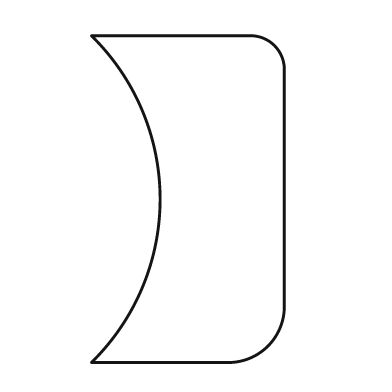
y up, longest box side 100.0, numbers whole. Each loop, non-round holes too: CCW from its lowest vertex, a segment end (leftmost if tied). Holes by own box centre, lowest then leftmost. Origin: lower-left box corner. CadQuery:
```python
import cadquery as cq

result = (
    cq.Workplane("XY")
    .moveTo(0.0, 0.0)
    .lineTo(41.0, 0.0)
    .threePointArc((54.0, 5.0), (59.0, 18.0))
    .lineTo(59.0, 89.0)
    .threePointArc((56.0, 97.0), (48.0, 100.0))
    .lineTo(0.0, 100.0)
    .threePointArc((21.0, 50.0), (0.0, 0.0))
    .close()
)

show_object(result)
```